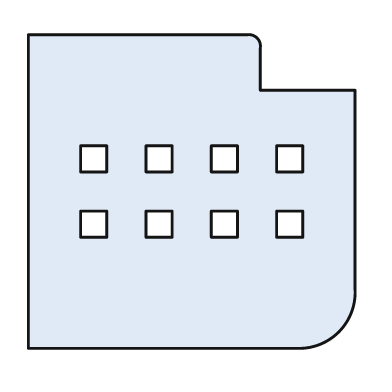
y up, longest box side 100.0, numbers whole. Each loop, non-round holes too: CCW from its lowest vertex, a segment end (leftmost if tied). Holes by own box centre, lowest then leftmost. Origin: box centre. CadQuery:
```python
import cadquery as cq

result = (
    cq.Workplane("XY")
    .moveTo(-50.0, -48.0)
    .lineTo(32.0, -48.0)
    .threePointArc((45.0, -43.0), (50.0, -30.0))
    .lineTo(50.0, 31.0)
    .lineTo(21.0, 31.0)
    .lineTo(21.0, 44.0)
    .threePointArc((20.0, 47.0), (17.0, 48.0))
    .lineTo(-50.0, 48.0)
    .close()
    .moveTo(-34.0, -14.0)
    .lineTo(-26.0, -14.0)
    .lineTo(-26.0, -6.0)
    .lineTo(-34.0, -6.0)
    .close()
    .moveTo(-14.0, -14.0)
    .lineTo(-6.0, -14.0)
    .lineTo(-6.0, -6.0)
    .lineTo(-14.0, -6.0)
    .close()
    .moveTo(6.0, -14.0)
    .lineTo(14.0, -14.0)
    .lineTo(14.0, -6.0)
    .lineTo(6.0, -6.0)
    .close()
    .moveTo(26.0, -14.0)
    .lineTo(34.0, -14.0)
    .lineTo(34.0, -6.0)
    .lineTo(26.0, -6.0)
    .close()
    .moveTo(-34.0, 6.0)
    .lineTo(-26.0, 6.0)
    .lineTo(-26.0, 14.0)
    .lineTo(-34.0, 14.0)
    .close()
    .moveTo(-14.0, 6.0)
    .lineTo(-6.0, 6.0)
    .lineTo(-6.0, 14.0)
    .lineTo(-14.0, 14.0)
    .close()
    .moveTo(6.0, 6.0)
    .lineTo(14.0, 6.0)
    .lineTo(14.0, 14.0)
    .lineTo(6.0, 14.0)
    .close()
    .moveTo(26.0, 6.0)
    .lineTo(34.0, 6.0)
    .lineTo(34.0, 14.0)
    .lineTo(26.0, 14.0)
    .close()
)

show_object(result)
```